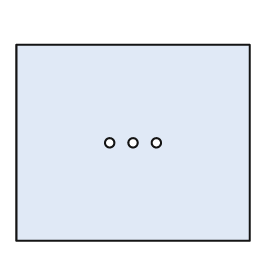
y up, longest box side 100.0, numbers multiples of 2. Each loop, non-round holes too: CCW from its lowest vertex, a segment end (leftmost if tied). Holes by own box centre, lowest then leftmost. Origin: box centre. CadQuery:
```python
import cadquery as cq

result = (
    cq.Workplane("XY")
    .moveTo(-50.0, -42.0)
    .lineTo(50.0, -42.0)
    .lineTo(50.0, 42.0)
    .lineTo(-50.0, 42.0)
    .close()
    .moveTo(-10.0, 0.0)
    .circle(2.0)
    .moveTo(0.0, 0.0)
    .circle(2.0)
    .moveTo(10.0, 0.0)
    .circle(2.0)
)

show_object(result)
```